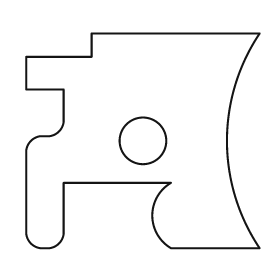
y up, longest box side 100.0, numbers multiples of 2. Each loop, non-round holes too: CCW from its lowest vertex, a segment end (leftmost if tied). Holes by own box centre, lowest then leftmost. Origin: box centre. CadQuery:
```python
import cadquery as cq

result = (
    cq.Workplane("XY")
    .moveTo(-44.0, -46.0)
    .lineTo(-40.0, -46.0)
    .threePointArc((-36.0, -44.0), (-34.0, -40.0))
    .lineTo(-34.0, -18.0)
    .lineTo(12.0, -18.0)
    .threePointArc((4.0, -32.0), (12.0, -46.0))
    .lineTo(50.0, -46.0)
    .threePointArc((36.0, 0.0), (50.0, 46.0))
    .lineTo(-22.0, 46.0)
    .lineTo(-22.0, 36.0)
    .lineTo(-50.0, 36.0)
    .lineTo(-50.0, 22.0)
    .lineTo(-34.0, 22.0)
    .lineTo(-34.0, 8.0)
    .threePointArc((-36.0, 4.0), (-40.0, 2.0))
    .lineTo(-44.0, 2.0)
    .threePointArc((-48.0, 0.0), (-50.0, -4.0))
    .lineTo(-50.0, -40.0)
    .threePointArc((-48.0, -44.0), (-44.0, -46.0))
    .close()
    .moveTo(0.0, 0.0)
    .circle(10.0)
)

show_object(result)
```